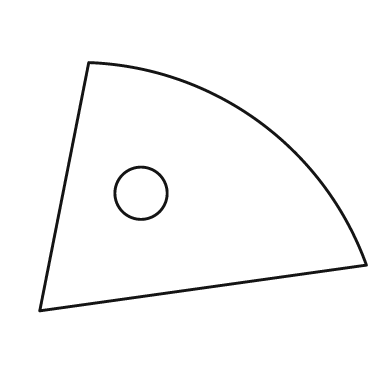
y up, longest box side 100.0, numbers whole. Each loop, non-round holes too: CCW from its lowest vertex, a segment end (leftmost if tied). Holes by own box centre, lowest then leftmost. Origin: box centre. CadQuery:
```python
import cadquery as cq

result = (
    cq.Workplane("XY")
    .moveTo(-50.0, -38.0)
    .lineTo(50.0, -24.0)
    .threePointArc((17.0, 20.0), (-35.0, 38.0))
    .close()
    .moveTo(-19.0, -2.0)
    .circle(8.0)
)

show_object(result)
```